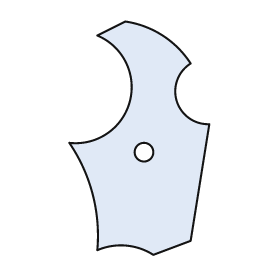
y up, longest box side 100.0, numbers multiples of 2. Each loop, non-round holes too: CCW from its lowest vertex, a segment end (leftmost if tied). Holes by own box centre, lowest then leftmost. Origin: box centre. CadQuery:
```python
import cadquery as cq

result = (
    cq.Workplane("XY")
    .moveTo(6.0, -50.0)
    .lineTo(22.0, -44.0)
    .lineTo(30.0, 6.0)
    .threePointArc((16.0, 16.0), (22.0, 32.0))
    .threePointArc((10.0, 44.0), (-6.0, 50.0))
    .lineTo(-18.0, 44.0)
    .threePointArc((-4.0, 16.0), (-30.0, -2.0))
    .threePointArc((-20.0, -24.0), (-18.0, -48.0))
    .threePointArc((-6.0, -46.0), (6.0, -50.0))
    .close()
    .moveTo(2.0, -6.0)
    .circle(4.0)
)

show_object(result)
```